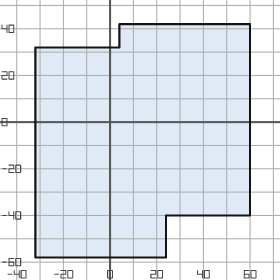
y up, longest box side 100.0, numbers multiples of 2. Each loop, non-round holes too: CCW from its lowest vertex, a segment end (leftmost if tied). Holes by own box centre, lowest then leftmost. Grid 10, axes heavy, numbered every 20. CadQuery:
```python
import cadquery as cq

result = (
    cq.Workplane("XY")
    .moveTo(-32.0, -58.0)
    .lineTo(24.0, -58.0)
    .lineTo(24.0, -40.0)
    .lineTo(60.0, -40.0)
    .lineTo(60.0, 42.0)
    .lineTo(4.0, 42.0)
    .lineTo(4.0, 32.0)
    .lineTo(-32.0, 32.0)
    .close()
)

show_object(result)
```